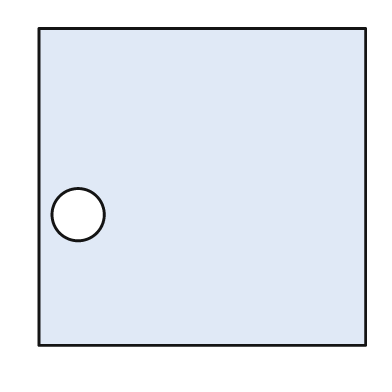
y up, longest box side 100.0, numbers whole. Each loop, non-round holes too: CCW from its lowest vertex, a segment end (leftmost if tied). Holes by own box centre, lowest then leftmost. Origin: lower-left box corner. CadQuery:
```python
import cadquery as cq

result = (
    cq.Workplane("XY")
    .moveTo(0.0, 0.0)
    .lineTo(100.0, 0.0)
    .lineTo(100.0, 97.0)
    .lineTo(0.0, 97.0)
    .close()
    .moveTo(12.0, 40.0)
    .circle(8.0)
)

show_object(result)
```